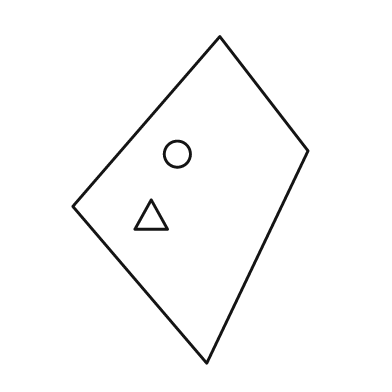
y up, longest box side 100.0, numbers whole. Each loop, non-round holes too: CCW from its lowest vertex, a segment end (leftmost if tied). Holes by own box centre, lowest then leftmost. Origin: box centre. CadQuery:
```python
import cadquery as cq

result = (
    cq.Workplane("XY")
    .moveTo(5.0, -50.0)
    .lineTo(36.0, 15.0)
    .lineTo(9.0, 50.0)
    .lineTo(-36.0, -2.0)
    .close()
    .moveTo(-17.0, -9.0)
    .lineTo(-7.0, -9.0)
    .lineTo(-12.0, 0.0)
    .close()
    .moveTo(-4.0, 14.0)
    .circle(4.0)
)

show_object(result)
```